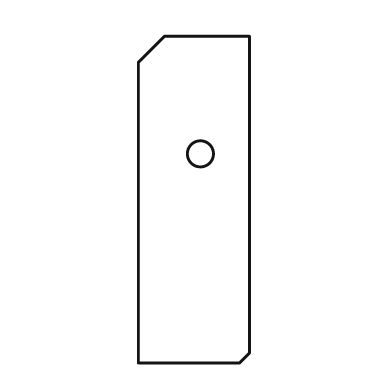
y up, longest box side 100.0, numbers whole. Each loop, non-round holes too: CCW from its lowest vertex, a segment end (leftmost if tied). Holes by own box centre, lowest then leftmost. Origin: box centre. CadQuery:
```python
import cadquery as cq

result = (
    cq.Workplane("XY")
    .moveTo(-17.0, -50.0)
    .lineTo(14.0, -50.0)
    .lineTo(17.0, -47.0)
    .lineTo(17.0, 50.0)
    .lineTo(-9.0, 50.0)
    .lineTo(-17.0, 42.0)
    .close()
    .moveTo(2.0, 14.0)
    .circle(4.0)
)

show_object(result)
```